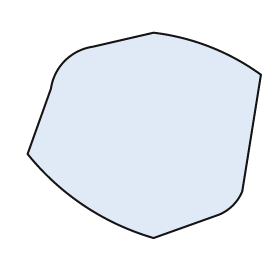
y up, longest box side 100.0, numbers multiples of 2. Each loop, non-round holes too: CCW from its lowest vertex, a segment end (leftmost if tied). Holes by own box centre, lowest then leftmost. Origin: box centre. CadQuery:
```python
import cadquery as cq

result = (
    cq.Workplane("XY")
    .moveTo(4.0, -44.0)
    .lineTo(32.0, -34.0)
    .threePointArc((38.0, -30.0), (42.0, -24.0))
    .lineTo(50.0, 26.0)
    .threePointArc((28.0, 38.0), (4.0, 44.0))
    .lineTo(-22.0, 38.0)
    .threePointArc((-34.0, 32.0), (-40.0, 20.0))
    .lineTo(-50.0, -8.0)
    .threePointArc((-26.0, -30.0), (4.0, -44.0))
    .close()
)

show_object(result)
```